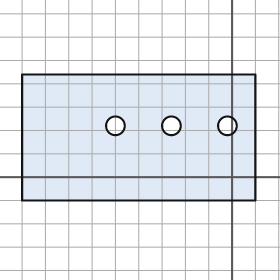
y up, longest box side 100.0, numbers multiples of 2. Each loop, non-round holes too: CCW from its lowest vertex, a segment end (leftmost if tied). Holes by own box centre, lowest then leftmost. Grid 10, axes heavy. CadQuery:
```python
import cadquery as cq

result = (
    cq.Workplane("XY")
    .moveTo(-90.0, -10.0)
    .lineTo(10.0, -10.0)
    .lineTo(10.0, 44.0)
    .lineTo(-90.0, 44.0)
    .close()
    .moveTo(-50.0, 22.0)
    .circle(4.0)
    .moveTo(-26.0, 22.0)
    .circle(4.0)
    .moveTo(-2.0, 22.0)
    .circle(4.0)
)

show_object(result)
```